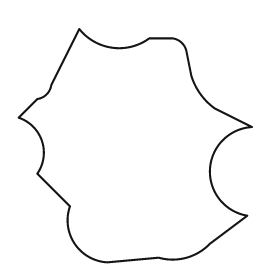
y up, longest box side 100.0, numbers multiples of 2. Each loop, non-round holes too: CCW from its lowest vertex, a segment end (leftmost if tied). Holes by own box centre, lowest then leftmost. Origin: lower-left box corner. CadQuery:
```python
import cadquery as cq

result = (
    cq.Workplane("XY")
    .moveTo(38.0, 0.0)
    .lineTo(60.0, 2.0)
    .threePointArc((72.0, 2.0), (82.0, 8.0))
    .lineTo(98.0, 20.0)
    .threePointArc((82.0, 40.0), (100.0, 58.0))
    .lineTo(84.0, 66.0)
    .threePointArc((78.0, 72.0), (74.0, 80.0))
    .lineTo(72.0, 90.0)
    .threePointArc((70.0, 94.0), (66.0, 96.0))
    .lineTo(56.0, 96.0)
    .threePointArc((40.0, 92.0), (26.0, 100.0))
    .lineTo(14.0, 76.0)
    .threePointArc((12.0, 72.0), (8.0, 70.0))
    .lineTo(0.0, 62.0)
    .threePointArc((10.0, 52.0), (8.0, 38.0))
    .lineTo(22.0, 24.0)
    .threePointArc((24.0, 8.0), (38.0, 0.0))
    .close()
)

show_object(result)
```